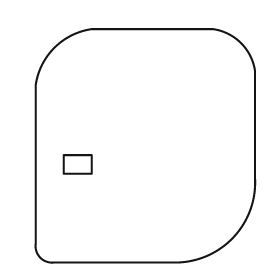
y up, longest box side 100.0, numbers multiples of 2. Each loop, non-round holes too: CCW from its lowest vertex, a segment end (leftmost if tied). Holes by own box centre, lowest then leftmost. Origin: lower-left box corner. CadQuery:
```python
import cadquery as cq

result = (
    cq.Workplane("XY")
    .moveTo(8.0, 0.0)
    .lineTo(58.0, 0.0)
    .threePointArc((84.0, 10.0), (94.0, 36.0))
    .lineTo(94.0, 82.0)
    .threePointArc((88.0, 94.0), (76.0, 100.0))
    .lineTo(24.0, 100.0)
    .threePointArc((8.0, 92.0), (0.0, 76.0))
    .lineTo(0.0, 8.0)
    .threePointArc((2.0, 2.0), (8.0, 0.0))
    .close()
    .moveTo(12.0, 38.0)
    .lineTo(24.0, 38.0)
    .lineTo(24.0, 46.0)
    .lineTo(12.0, 46.0)
    .close()
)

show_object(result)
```